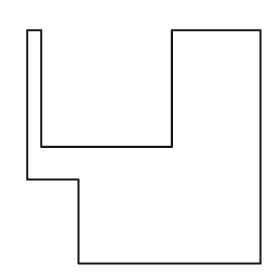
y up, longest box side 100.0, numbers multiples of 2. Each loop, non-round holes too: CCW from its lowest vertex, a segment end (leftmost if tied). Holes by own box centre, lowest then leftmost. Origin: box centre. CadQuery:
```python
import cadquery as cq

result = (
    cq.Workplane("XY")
    .moveTo(-28.0, -50.0)
    .lineTo(50.0, -50.0)
    .lineTo(50.0, 50.0)
    .lineTo(12.0, 50.0)
    .lineTo(12.0, 0.0)
    .lineTo(-44.0, 0.0)
    .lineTo(-44.0, 50.0)
    .lineTo(-50.0, 50.0)
    .lineTo(-50.0, -14.0)
    .lineTo(-28.0, -14.0)
    .close()
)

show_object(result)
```